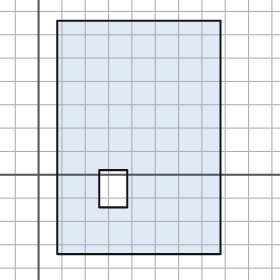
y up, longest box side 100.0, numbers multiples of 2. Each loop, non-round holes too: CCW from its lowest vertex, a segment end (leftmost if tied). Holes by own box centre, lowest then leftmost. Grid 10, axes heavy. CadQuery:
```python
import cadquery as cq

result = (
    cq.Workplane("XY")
    .moveTo(8.0, -34.0)
    .lineTo(78.0, -34.0)
    .lineTo(78.0, 66.0)
    .lineTo(8.0, 66.0)
    .close()
    .moveTo(26.0, -14.0)
    .lineTo(38.0, -14.0)
    .lineTo(38.0, 2.0)
    .lineTo(26.0, 2.0)
    .close()
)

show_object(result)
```